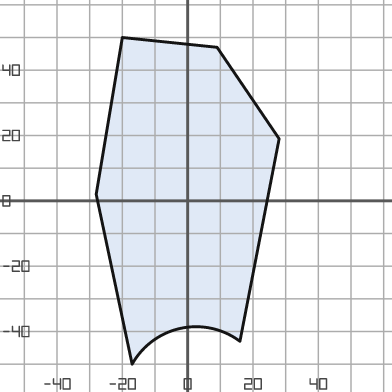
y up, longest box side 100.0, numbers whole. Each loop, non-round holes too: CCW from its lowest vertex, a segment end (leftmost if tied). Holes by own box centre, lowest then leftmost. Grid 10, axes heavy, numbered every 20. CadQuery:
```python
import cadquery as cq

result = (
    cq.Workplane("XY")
    .moveTo(-17.0, -50.0)
    .threePointArc((-2.0, -39.0), (16.0, -43.0))
    .lineTo(28.0, 19.0)
    .lineTo(9.0, 47.0)
    .lineTo(-20.0, 50.0)
    .lineTo(-28.0, 2.0)
    .close()
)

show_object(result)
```